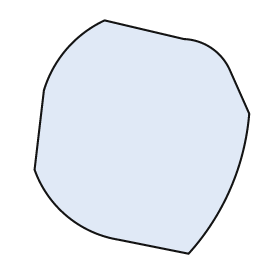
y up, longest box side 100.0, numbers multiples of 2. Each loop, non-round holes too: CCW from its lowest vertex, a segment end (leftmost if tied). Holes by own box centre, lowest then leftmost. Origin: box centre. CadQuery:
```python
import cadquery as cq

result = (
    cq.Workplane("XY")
    .moveTo(20.0, -50.0)
    .threePointArc((38.0, -22.0), (46.0, 10.0))
    .lineTo(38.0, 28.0)
    .threePointArc((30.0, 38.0), (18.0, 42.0))
    .lineTo(-16.0, 50.0)
    .threePointArc((-32.0, 38.0), (-42.0, 20.0))
    .lineTo(-46.0, -14.0)
    .threePointArc((-32.0, -34.0), (-10.0, -44.0))
    .close()
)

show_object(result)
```